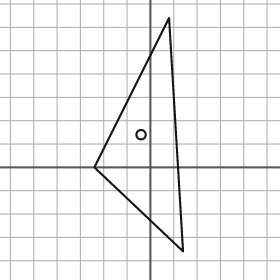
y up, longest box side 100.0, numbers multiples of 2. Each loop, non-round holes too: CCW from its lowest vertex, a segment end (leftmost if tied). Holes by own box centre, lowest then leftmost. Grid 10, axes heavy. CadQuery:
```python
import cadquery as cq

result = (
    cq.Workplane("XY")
    .moveTo(14.0, -36.0)
    .lineTo(8.0, 64.0)
    .lineTo(-24.0, 0.0)
    .close()
    .moveTo(-4.0, 14.0)
    .circle(2.0)
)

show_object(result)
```